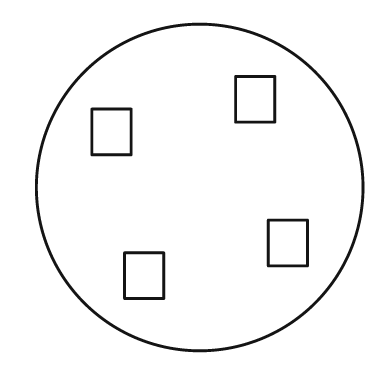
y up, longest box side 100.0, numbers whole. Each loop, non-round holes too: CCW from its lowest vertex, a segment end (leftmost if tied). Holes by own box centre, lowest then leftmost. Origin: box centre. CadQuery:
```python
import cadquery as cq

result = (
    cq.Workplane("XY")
    .moveTo(0.0, 0.0)
    .circle(50.0)
    .moveTo(-23.0, -34.0)
    .lineTo(-11.0, -34.0)
    .lineTo(-11.0, -20.0)
    .lineTo(-23.0, -20.0)
    .close()
    .moveTo(21.0, -24.0)
    .lineTo(33.0, -24.0)
    .lineTo(33.0, -10.0)
    .lineTo(21.0, -10.0)
    .close()
    .moveTo(-33.0, 10.0)
    .lineTo(-21.0, 10.0)
    .lineTo(-21.0, 24.0)
    .lineTo(-33.0, 24.0)
    .close()
    .moveTo(11.0, 20.0)
    .lineTo(23.0, 20.0)
    .lineTo(23.0, 34.0)
    .lineTo(11.0, 34.0)
    .close()
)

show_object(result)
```